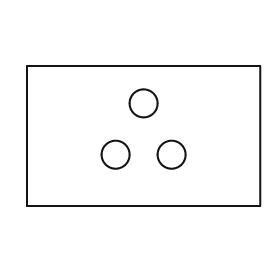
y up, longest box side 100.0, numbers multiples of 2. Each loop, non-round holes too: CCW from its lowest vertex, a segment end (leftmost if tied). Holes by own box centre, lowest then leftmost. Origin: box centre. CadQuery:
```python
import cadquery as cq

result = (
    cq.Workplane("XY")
    .moveTo(-50.0, -30.0)
    .lineTo(50.0, -30.0)
    .lineTo(50.0, 30.0)
    .lineTo(-50.0, 30.0)
    .close()
    .moveTo(-12.0, -8.0)
    .circle(6.0)
    .moveTo(12.0, -8.0)
    .circle(6.0)
    .moveTo(0.0, 14.0)
    .circle(6.0)
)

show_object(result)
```